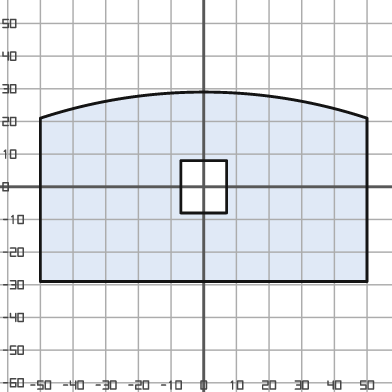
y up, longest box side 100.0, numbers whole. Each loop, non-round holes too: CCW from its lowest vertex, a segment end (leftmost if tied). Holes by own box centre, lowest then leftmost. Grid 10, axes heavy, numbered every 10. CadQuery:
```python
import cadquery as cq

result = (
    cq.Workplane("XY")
    .moveTo(-50.0, -29.0)
    .lineTo(50.0, -29.0)
    .lineTo(50.0, 21.0)
    .threePointArc((0.0, 29.0), (-50.0, 21.0))
    .close()
    .moveTo(-7.0, -8.0)
    .lineTo(7.0, -8.0)
    .lineTo(7.0, 8.0)
    .lineTo(-7.0, 8.0)
    .close()
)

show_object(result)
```